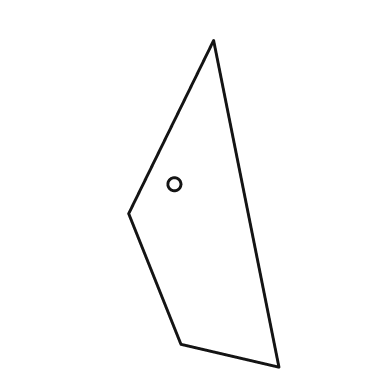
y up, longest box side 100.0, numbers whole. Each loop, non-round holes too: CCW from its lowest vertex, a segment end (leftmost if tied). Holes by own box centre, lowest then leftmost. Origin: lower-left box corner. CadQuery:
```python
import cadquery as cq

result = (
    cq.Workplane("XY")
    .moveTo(46.0, 0.0)
    .lineTo(26.0, 100.0)
    .lineTo(0.0, 47.0)
    .lineTo(16.0, 7.0)
    .close()
    .moveTo(14.0, 56.0)
    .circle(2.0)
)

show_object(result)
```